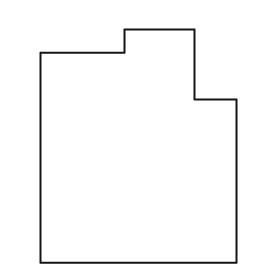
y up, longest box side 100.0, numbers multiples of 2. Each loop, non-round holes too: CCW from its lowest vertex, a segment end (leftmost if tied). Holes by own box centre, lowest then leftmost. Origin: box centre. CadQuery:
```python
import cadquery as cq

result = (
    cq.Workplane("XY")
    .moveTo(-42.0, -50.0)
    .lineTo(42.0, -50.0)
    .lineTo(42.0, 20.0)
    .lineTo(24.0, 20.0)
    .lineTo(24.0, 50.0)
    .lineTo(-6.0, 50.0)
    .lineTo(-6.0, 40.0)
    .lineTo(-42.0, 40.0)
    .close()
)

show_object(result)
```